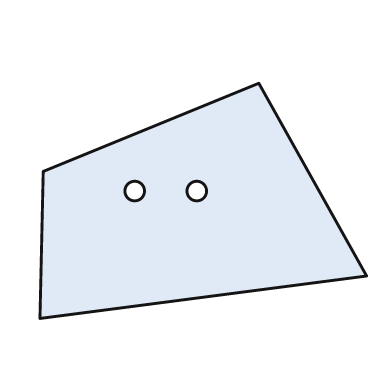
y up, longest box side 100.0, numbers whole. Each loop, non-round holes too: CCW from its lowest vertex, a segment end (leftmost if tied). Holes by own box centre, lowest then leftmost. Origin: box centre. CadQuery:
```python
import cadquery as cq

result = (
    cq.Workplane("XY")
    .moveTo(-50.0, -36.0)
    .lineTo(50.0, -23.0)
    .lineTo(17.0, 36.0)
    .lineTo(-49.0, 9.0)
    .close()
    .moveTo(-21.0, 3.0)
    .circle(3.0)
    .moveTo(-2.0, 3.0)
    .circle(3.0)
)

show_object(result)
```